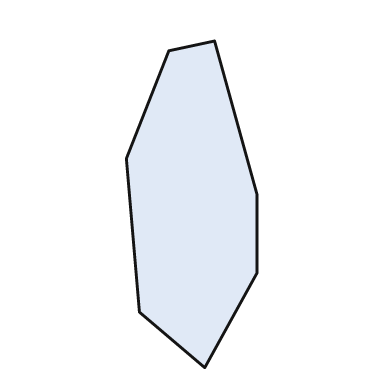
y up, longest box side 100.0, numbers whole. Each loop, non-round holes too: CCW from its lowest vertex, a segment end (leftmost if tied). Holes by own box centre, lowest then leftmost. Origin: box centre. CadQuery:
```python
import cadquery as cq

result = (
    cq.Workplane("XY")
    .moveTo(4.0, -50.0)
    .lineTo(20.0, -21.0)
    .lineTo(20.0, 3.0)
    .lineTo(7.0, 50.0)
    .lineTo(-7.0, 47.0)
    .lineTo(-20.0, 14.0)
    .lineTo(-16.0, -33.0)
    .close()
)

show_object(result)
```